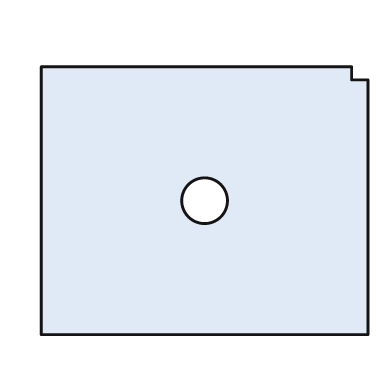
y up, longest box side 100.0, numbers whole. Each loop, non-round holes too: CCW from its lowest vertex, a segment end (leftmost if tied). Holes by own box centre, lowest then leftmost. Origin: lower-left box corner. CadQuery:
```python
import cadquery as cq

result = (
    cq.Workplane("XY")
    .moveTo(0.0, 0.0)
    .lineTo(100.0, 0.0)
    .lineTo(100.0, 78.0)
    .lineTo(95.0, 78.0)
    .lineTo(95.0, 82.0)
    .lineTo(0.0, 82.0)
    .close()
    .moveTo(50.0, 41.0)
    .circle(7.0)
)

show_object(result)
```